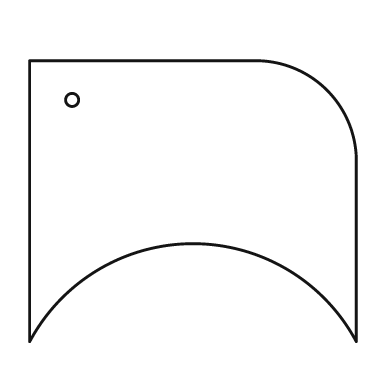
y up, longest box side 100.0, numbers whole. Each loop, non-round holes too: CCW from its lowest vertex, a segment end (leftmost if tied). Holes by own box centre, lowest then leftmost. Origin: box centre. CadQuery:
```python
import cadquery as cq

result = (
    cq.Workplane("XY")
    .moveTo(-50.0, -43.0)
    .threePointArc((0.0, -13.0), (50.0, -43.0))
    .lineTo(50.0, 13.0)
    .threePointArc((41.0, 34.0), (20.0, 43.0))
    .lineTo(-50.0, 43.0)
    .close()
    .moveTo(-37.0, 31.0)
    .circle(2.0)
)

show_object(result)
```